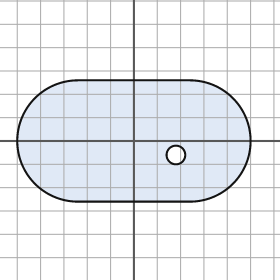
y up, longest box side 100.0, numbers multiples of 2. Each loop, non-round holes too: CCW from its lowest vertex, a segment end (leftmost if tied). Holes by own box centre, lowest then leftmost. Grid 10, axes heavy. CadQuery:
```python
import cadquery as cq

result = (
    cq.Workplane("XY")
    .moveTo(-24.0, -26.0)
    .lineTo(24.0, -26.0)
    .threePointArc((50.0, 0.0), (24.0, 26.0))
    .lineTo(-24.0, 26.0)
    .threePointArc((-50.0, 0.0), (-24.0, -26.0))
    .close()
    .moveTo(18.0, -6.0)
    .circle(4.0)
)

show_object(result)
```